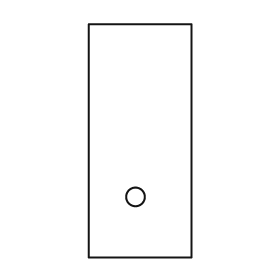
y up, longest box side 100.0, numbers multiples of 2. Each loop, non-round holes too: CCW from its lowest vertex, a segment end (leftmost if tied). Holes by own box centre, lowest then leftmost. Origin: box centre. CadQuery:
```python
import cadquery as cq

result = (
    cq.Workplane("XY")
    .moveTo(-22.0, -50.0)
    .lineTo(22.0, -50.0)
    .lineTo(22.0, 50.0)
    .lineTo(-22.0, 50.0)
    .close()
    .moveTo(-2.0, -24.0)
    .circle(4.0)
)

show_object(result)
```